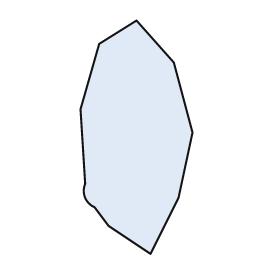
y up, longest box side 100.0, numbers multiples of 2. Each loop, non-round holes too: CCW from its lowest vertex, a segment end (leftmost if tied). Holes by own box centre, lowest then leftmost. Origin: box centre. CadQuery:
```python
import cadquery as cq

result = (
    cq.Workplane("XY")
    .moveTo(6.0, -50.0)
    .lineTo(18.0, -26.0)
    .lineTo(24.0, 2.0)
    .lineTo(16.0, 32.0)
    .lineTo(0.0, 50.0)
    .lineTo(-16.0, 40.0)
    .lineTo(-24.0, 12.0)
    .lineTo(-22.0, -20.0)
    .threePointArc((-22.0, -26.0), (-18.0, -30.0))
    .lineTo(-12.0, -38.0)
    .close()
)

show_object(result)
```